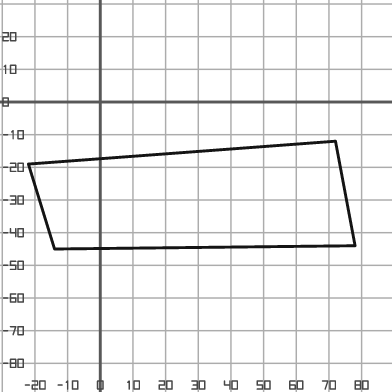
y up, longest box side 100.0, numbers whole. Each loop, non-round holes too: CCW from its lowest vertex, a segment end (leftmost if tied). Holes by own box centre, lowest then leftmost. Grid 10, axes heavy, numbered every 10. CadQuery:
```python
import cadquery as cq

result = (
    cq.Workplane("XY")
    .moveTo(-14.0, -45.0)
    .lineTo(78.0, -44.0)
    .lineTo(72.0, -12.0)
    .lineTo(-22.0, -19.0)
    .close()
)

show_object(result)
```